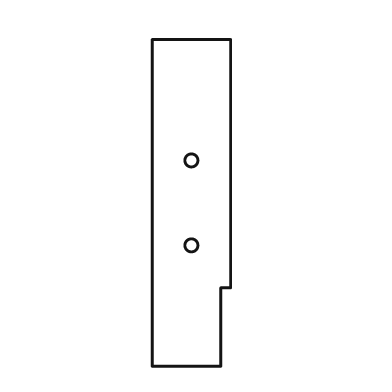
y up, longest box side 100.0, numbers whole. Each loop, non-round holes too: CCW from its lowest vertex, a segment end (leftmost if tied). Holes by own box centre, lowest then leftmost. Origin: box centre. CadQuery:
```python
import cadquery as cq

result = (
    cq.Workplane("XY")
    .moveTo(-12.0, -50.0)
    .lineTo(9.0, -50.0)
    .lineTo(9.0, -26.0)
    .lineTo(12.0, -26.0)
    .lineTo(12.0, 50.0)
    .lineTo(-12.0, 50.0)
    .close()
    .moveTo(0.0, -13.0)
    .circle(2.0)
    .moveTo(0.0, 13.0)
    .circle(2.0)
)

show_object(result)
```